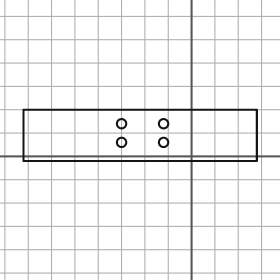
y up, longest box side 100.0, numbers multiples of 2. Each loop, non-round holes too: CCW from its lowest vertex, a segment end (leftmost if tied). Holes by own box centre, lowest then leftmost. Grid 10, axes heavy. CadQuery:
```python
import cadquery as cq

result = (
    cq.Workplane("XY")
    .moveTo(-72.0, -2.0)
    .lineTo(28.0, -2.0)
    .lineTo(28.0, 20.0)
    .lineTo(-72.0, 20.0)
    .close()
    .moveTo(-30.0, 6.0)
    .circle(2.0)
    .moveTo(-12.0, 6.0)
    .circle(2.0)
    .moveTo(-30.0, 14.0)
    .circle(2.0)
    .moveTo(-12.0, 14.0)
    .circle(2.0)
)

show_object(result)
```